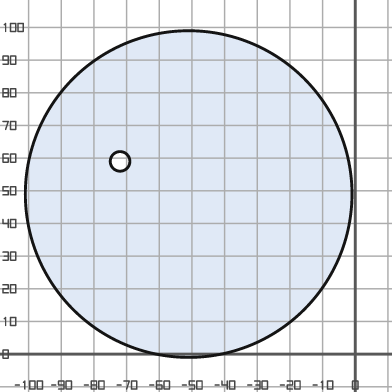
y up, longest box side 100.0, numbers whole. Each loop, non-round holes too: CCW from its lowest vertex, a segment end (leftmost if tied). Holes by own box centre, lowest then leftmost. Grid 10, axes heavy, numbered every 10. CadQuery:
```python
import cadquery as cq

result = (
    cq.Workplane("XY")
    .moveTo(-51.0, 49.0)
    .circle(50.0)
    .moveTo(-72.0, 59.0)
    .circle(3.0)
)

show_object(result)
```